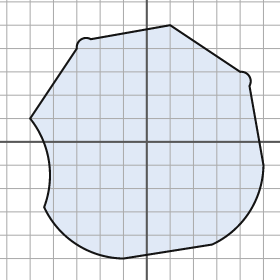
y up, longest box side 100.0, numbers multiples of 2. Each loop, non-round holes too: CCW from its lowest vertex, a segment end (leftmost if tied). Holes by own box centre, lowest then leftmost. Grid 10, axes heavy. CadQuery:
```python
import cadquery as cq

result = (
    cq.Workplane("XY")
    .moveTo(-10.0, -50.0)
    .lineTo(28.0, -44.0)
    .threePointArc((44.0, -30.0), (50.0, -10.0))
    .lineTo(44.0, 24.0)
    .threePointArc((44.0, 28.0), (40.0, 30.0))
    .lineTo(10.0, 50.0)
    .lineTo(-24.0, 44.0)
    .threePointArc((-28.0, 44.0), (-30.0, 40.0))
    .lineTo(-50.0, 10.0)
    .threePointArc((-42.0, -8.0), (-44.0, -28.0))
    .threePointArc((-30.0, -44.0), (-10.0, -50.0))
    .close()
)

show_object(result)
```